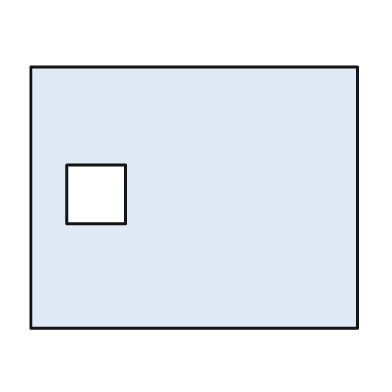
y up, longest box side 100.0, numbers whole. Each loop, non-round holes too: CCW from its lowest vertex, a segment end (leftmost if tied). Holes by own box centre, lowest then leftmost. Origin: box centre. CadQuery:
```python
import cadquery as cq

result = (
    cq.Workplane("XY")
    .moveTo(-50.0, -40.0)
    .lineTo(50.0, -40.0)
    .lineTo(50.0, 40.0)
    .lineTo(-50.0, 40.0)
    .close()
    .moveTo(-39.0, -8.0)
    .lineTo(-21.0, -8.0)
    .lineTo(-21.0, 10.0)
    .lineTo(-39.0, 10.0)
    .close()
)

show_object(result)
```